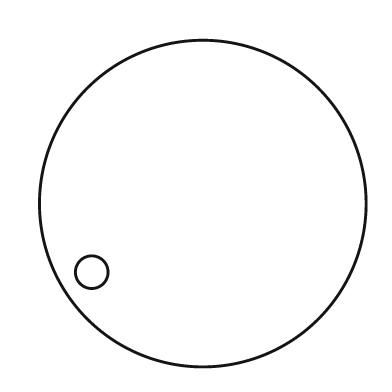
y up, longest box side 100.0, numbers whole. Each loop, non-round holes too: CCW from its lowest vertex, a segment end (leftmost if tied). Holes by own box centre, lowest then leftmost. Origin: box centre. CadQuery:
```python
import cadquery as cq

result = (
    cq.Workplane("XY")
    .moveTo(0.0, 0.0)
    .circle(50.0)
    .moveTo(-34.0, -21.0)
    .circle(5.0)
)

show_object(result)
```